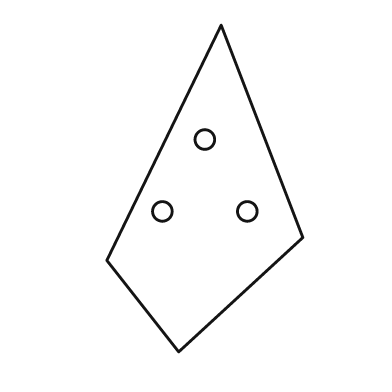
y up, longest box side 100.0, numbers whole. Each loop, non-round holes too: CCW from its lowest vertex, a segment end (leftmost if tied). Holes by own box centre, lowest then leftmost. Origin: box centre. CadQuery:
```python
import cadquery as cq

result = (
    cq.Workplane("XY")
    .moveTo(-8.0, -50.0)
    .lineTo(30.0, -15.0)
    .lineTo(5.0, 50.0)
    .lineTo(-30.0, -22.0)
    .close()
    .moveTo(-13.0, -7.0)
    .circle(3.0)
    .moveTo(13.0, -7.0)
    .circle(3.0)
    .moveTo(0.0, 15.0)
    .circle(3.0)
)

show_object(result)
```